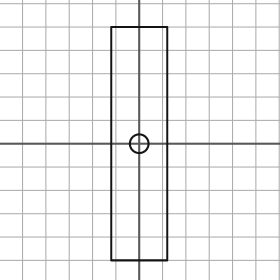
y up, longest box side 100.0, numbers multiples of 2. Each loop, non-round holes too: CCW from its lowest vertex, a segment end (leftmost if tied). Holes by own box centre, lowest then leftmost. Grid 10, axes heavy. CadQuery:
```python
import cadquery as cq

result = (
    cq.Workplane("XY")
    .moveTo(-12.0, -50.0)
    .lineTo(12.0, -50.0)
    .lineTo(12.0, 50.0)
    .lineTo(-12.0, 50.0)
    .close()
    .moveTo(0.0, 0.0)
    .circle(4.0)
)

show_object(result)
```